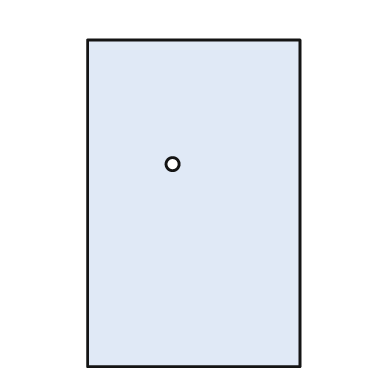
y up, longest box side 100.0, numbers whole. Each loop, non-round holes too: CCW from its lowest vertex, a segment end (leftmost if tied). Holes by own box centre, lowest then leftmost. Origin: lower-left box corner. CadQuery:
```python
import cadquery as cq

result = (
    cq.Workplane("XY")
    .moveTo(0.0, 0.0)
    .lineTo(65.0, 0.0)
    .lineTo(65.0, 100.0)
    .lineTo(0.0, 100.0)
    .close()
    .moveTo(26.0, 62.0)
    .circle(2.0)
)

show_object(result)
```